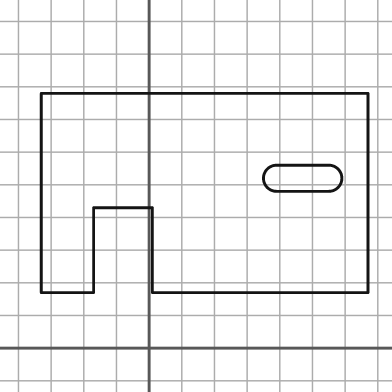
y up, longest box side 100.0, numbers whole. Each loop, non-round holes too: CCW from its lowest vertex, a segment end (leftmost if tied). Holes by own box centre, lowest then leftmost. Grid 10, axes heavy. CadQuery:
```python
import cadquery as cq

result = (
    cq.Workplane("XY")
    .moveTo(-33.0, 17.0)
    .lineTo(-17.0, 17.0)
    .lineTo(-17.0, 43.0)
    .lineTo(1.0, 43.0)
    .lineTo(1.0, 17.0)
    .lineTo(67.0, 17.0)
    .lineTo(67.0, 78.0)
    .lineTo(-33.0, 78.0)
    .close()
    .moveTo(39.0, 48.0)
    .lineTo(55.0, 48.0)
    .threePointArc((59.0, 52.0), (55.0, 56.0))
    .lineTo(39.0, 56.0)
    .threePointArc((35.0, 52.0), (39.0, 48.0))
    .close()
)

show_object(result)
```